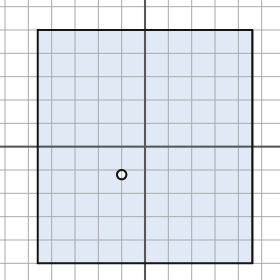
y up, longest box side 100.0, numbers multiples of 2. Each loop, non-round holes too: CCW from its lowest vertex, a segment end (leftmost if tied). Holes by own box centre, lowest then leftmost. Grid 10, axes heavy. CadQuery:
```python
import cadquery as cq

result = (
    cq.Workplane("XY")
    .moveTo(-46.0, -50.0)
    .lineTo(46.0, -50.0)
    .lineTo(46.0, 50.0)
    .lineTo(-46.0, 50.0)
    .close()
    .moveTo(-10.0, -12.0)
    .circle(2.0)
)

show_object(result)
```